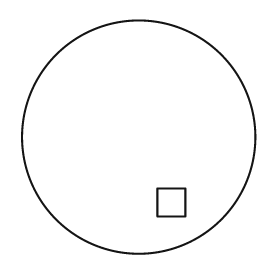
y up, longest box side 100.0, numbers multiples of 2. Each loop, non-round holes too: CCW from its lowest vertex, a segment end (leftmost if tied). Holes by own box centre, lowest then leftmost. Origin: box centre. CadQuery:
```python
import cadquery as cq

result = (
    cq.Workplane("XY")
    .moveTo(0.0, 0.0)
    .circle(50.0)
    .moveTo(8.0, -34.0)
    .lineTo(20.0, -34.0)
    .lineTo(20.0, -22.0)
    .lineTo(8.0, -22.0)
    .close()
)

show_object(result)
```